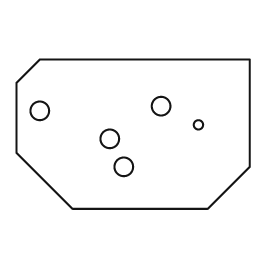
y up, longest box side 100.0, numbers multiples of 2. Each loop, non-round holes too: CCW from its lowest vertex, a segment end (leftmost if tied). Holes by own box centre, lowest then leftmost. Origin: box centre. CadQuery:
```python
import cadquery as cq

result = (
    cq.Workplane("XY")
    .moveTo(-26.0, -32.0)
    .lineTo(32.0, -32.0)
    .lineTo(50.0, -14.0)
    .lineTo(50.0, 32.0)
    .lineTo(-40.0, 32.0)
    .lineTo(-50.0, 22.0)
    .lineTo(-50.0, -8.0)
    .close()
    .moveTo(-4.0, -14.0)
    .circle(4.0)
    .moveTo(-10.0, -2.0)
    .circle(4.0)
    .moveTo(28.0, 4.0)
    .circle(2.0)
    .moveTo(-40.0, 10.0)
    .circle(4.0)
    .moveTo(12.0, 12.0)
    .circle(4.0)
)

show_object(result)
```